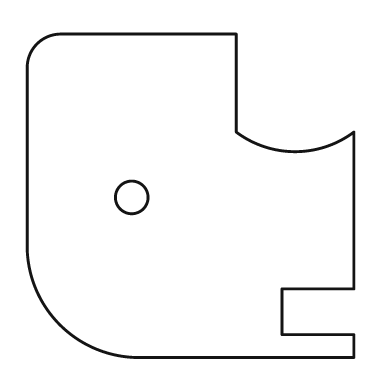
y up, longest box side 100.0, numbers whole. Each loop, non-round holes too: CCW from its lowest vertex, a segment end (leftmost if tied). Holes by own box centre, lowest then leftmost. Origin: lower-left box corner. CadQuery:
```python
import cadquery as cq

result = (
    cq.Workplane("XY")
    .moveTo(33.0, 0.0)
    .lineTo(100.0, 0.0)
    .lineTo(100.0, 7.0)
    .lineTo(78.0, 7.0)
    .lineTo(78.0, 21.0)
    .lineTo(100.0, 21.0)
    .lineTo(100.0, 69.0)
    .threePointArc((82.0, 63.0), (64.0, 69.0))
    .lineTo(64.0, 99.0)
    .lineTo(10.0, 99.0)
    .threePointArc((3.0, 96.0), (0.0, 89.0))
    .lineTo(0.0, 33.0)
    .threePointArc((10.0, 10.0), (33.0, 0.0))
    .close()
    .moveTo(32.0, 49.0)
    .circle(5.0)
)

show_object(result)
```